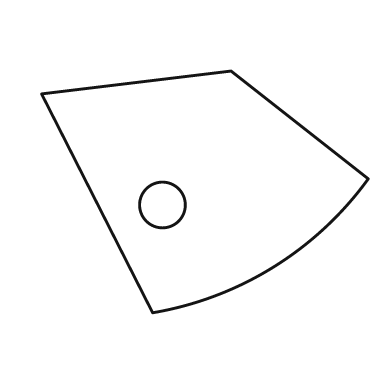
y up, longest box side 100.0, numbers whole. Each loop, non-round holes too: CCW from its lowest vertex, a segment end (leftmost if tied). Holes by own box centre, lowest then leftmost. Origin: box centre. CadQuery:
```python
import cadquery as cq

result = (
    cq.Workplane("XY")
    .moveTo(-16.0, -37.0)
    .threePointArc((21.0, -23.0), (50.0, 4.0))
    .lineTo(8.0, 37.0)
    .lineTo(-50.0, 30.0)
    .close()
    .moveTo(-13.0, -4.0)
    .circle(7.0)
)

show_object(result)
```